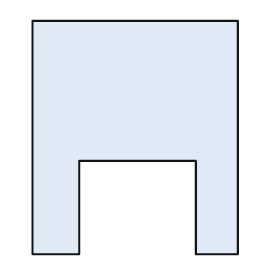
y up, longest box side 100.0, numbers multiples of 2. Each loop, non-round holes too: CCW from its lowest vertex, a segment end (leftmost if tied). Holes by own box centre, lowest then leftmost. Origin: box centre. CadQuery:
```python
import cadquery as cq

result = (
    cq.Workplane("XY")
    .moveTo(-44.0, -50.0)
    .lineTo(-24.0, -50.0)
    .lineTo(-24.0, -10.0)
    .lineTo(26.0, -10.0)
    .lineTo(26.0, -50.0)
    .lineTo(44.0, -50.0)
    .lineTo(44.0, 50.0)
    .lineTo(-44.0, 50.0)
    .close()
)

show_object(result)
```